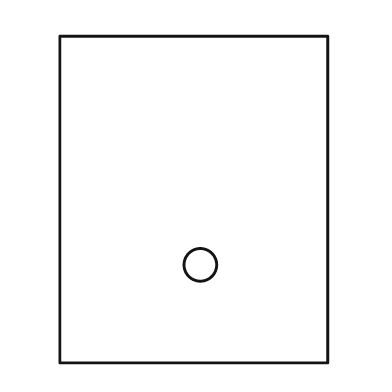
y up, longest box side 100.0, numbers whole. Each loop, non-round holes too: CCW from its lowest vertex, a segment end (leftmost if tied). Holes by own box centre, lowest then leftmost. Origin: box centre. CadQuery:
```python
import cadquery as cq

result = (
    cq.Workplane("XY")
    .moveTo(-41.0, -50.0)
    .lineTo(41.0, -50.0)
    .lineTo(41.0, 50.0)
    .lineTo(-41.0, 50.0)
    .close()
    .moveTo(2.0, -20.0)
    .circle(5.0)
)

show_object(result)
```